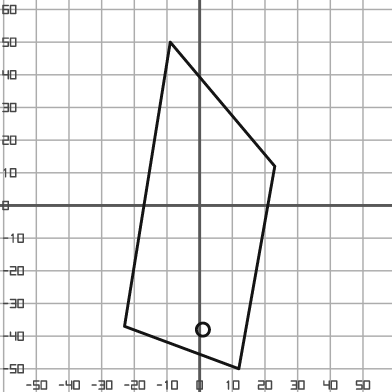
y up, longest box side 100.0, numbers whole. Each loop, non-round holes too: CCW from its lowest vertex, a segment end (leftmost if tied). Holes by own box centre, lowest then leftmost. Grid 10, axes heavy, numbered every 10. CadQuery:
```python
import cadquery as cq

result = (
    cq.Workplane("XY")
    .moveTo(12.0, -50.0)
    .lineTo(23.0, 12.0)
    .lineTo(-9.0, 50.0)
    .lineTo(-23.0, -37.0)
    .close()
    .moveTo(1.0, -38.0)
    .circle(2.0)
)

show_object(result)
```